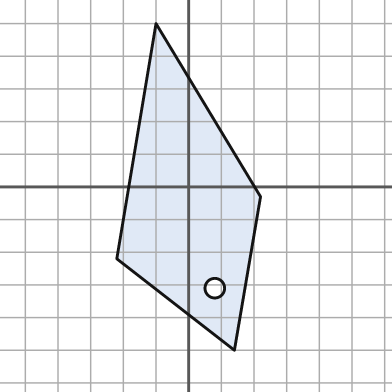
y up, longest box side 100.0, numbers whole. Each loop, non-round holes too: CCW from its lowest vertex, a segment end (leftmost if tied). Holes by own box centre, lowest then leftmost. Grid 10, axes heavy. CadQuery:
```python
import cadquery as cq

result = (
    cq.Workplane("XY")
    .moveTo(14.0, -50.0)
    .lineTo(22.0, -3.0)
    .lineTo(-10.0, 50.0)
    .lineTo(-22.0, -22.0)
    .close()
    .moveTo(8.0, -31.0)
    .circle(3.0)
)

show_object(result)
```